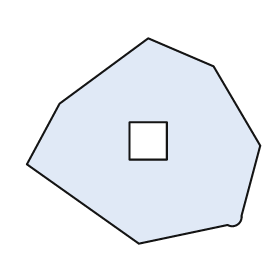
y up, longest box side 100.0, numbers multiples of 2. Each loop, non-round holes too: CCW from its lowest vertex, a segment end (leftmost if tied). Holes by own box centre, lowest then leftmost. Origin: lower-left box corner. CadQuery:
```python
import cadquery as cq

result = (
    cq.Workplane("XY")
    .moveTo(48.0, 0.0)
    .lineTo(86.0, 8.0)
    .threePointArc((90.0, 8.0), (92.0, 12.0))
    .lineTo(100.0, 42.0)
    .lineTo(80.0, 76.0)
    .lineTo(52.0, 88.0)
    .lineTo(14.0, 60.0)
    .lineTo(0.0, 34.0)
    .close()
    .moveTo(44.0, 36.0)
    .lineTo(60.0, 36.0)
    .lineTo(60.0, 52.0)
    .lineTo(44.0, 52.0)
    .close()
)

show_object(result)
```